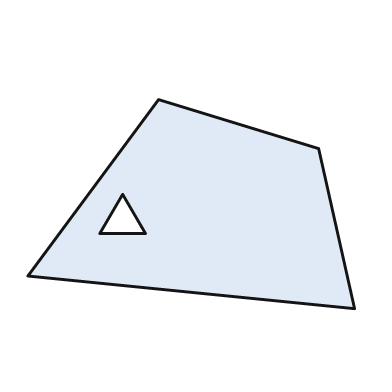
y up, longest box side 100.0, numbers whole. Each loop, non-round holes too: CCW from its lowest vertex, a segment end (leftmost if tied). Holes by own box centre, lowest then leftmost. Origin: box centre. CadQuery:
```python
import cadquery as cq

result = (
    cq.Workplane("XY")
    .moveTo(50.0, -32.0)
    .lineTo(39.0, 17.0)
    .lineTo(-10.0, 32.0)
    .lineTo(-50.0, -22.0)
    .close()
    .moveTo(-28.0, -9.0)
    .lineTo(-14.0, -9.0)
    .lineTo(-21.0, 3.0)
    .close()
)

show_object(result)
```